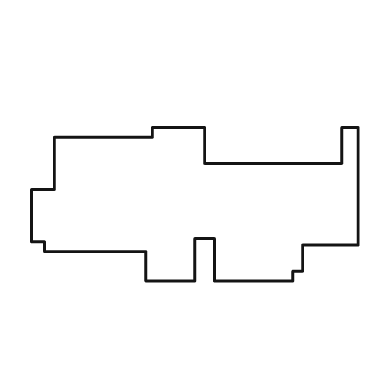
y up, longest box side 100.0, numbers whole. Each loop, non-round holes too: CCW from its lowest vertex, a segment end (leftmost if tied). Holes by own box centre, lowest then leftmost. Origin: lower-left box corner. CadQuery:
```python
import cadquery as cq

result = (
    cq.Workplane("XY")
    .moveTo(35.0, 0.0)
    .lineTo(50.0, 0.0)
    .lineTo(50.0, 13.0)
    .lineTo(56.0, 13.0)
    .lineTo(56.0, 0.0)
    .lineTo(80.0, 0.0)
    .lineTo(80.0, 3.0)
    .lineTo(83.0, 3.0)
    .lineTo(83.0, 11.0)
    .lineTo(100.0, 11.0)
    .lineTo(100.0, 47.0)
    .lineTo(95.0, 47.0)
    .lineTo(95.0, 36.0)
    .lineTo(53.0, 36.0)
    .lineTo(53.0, 47.0)
    .lineTo(37.0, 47.0)
    .lineTo(37.0, 44.0)
    .lineTo(7.0, 44.0)
    .lineTo(7.0, 28.0)
    .lineTo(0.0, 28.0)
    .lineTo(0.0, 12.0)
    .lineTo(4.0, 12.0)
    .lineTo(4.0, 9.0)
    .lineTo(35.0, 9.0)
    .close()
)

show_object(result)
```